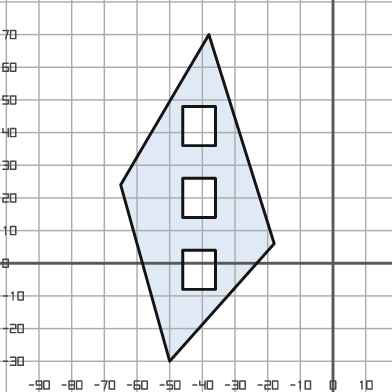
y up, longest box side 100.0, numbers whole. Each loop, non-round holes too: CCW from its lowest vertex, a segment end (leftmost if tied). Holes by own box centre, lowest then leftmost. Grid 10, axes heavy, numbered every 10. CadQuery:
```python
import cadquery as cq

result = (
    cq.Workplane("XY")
    .moveTo(-50.0, -30.0)
    .lineTo(-18.0, 6.0)
    .lineTo(-38.0, 70.0)
    .lineTo(-65.0, 24.0)
    .close()
    .moveTo(-46.0, -8.0)
    .lineTo(-36.0, -8.0)
    .lineTo(-36.0, 4.0)
    .lineTo(-46.0, 4.0)
    .close()
    .moveTo(-46.0, 14.0)
    .lineTo(-36.0, 14.0)
    .lineTo(-36.0, 26.0)
    .lineTo(-46.0, 26.0)
    .close()
    .moveTo(-46.0, 36.0)
    .lineTo(-36.0, 36.0)
    .lineTo(-36.0, 48.0)
    .lineTo(-46.0, 48.0)
    .close()
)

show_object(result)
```